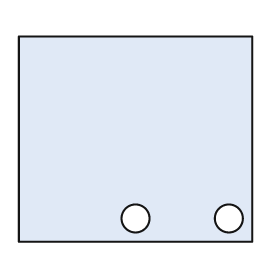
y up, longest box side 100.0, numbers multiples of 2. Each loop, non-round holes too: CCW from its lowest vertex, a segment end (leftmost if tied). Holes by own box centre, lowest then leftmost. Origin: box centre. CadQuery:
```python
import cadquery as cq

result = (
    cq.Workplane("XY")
    .moveTo(-50.0, -44.0)
    .lineTo(50.0, -44.0)
    .lineTo(50.0, 44.0)
    .lineTo(-50.0, 44.0)
    .close()
    .moveTo(0.0, -34.0)
    .circle(6.0)
    .moveTo(40.0, -34.0)
    .circle(6.0)
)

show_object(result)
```